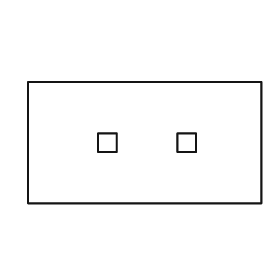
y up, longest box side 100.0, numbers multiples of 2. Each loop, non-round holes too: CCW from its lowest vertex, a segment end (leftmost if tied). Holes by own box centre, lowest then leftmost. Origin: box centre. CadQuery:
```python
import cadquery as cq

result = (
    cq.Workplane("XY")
    .moveTo(-50.0, -26.0)
    .lineTo(50.0, -26.0)
    .lineTo(50.0, 26.0)
    .lineTo(-50.0, 26.0)
    .close()
    .moveTo(-20.0, -4.0)
    .lineTo(-12.0, -4.0)
    .lineTo(-12.0, 4.0)
    .lineTo(-20.0, 4.0)
    .close()
    .moveTo(14.0, -4.0)
    .lineTo(22.0, -4.0)
    .lineTo(22.0, 4.0)
    .lineTo(14.0, 4.0)
    .close()
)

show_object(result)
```